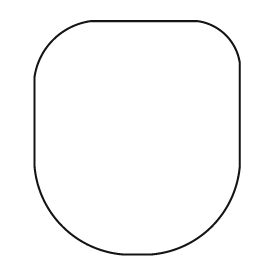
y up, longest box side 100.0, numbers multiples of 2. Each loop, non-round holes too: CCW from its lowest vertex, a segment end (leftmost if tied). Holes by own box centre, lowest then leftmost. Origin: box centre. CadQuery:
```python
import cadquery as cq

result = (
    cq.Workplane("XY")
    .moveTo(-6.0, -50.0)
    .lineTo(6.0, -50.0)
    .threePointArc((32.0, -38.0), (44.0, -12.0))
    .lineTo(44.0, 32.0)
    .threePointArc((38.0, 44.0), (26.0, 50.0))
    .lineTo(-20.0, 50.0)
    .threePointArc((-36.0, 42.0), (-44.0, 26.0))
    .lineTo(-44.0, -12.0)
    .threePointArc((-32.0, -38.0), (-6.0, -50.0))
    .close()
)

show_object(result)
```